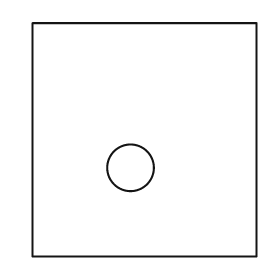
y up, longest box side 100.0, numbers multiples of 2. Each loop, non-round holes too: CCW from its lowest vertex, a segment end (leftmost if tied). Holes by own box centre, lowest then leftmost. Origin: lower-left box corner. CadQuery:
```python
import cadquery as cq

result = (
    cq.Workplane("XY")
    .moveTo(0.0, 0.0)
    .lineTo(96.0, 0.0)
    .lineTo(96.0, 100.0)
    .lineTo(0.0, 100.0)
    .close()
    .moveTo(42.0, 38.0)
    .circle(10.0)
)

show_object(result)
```